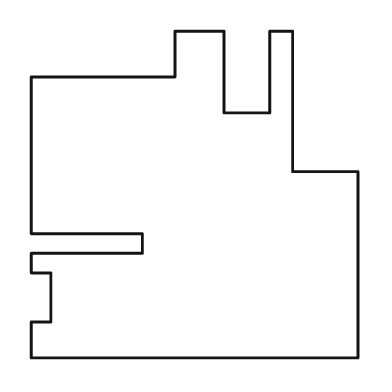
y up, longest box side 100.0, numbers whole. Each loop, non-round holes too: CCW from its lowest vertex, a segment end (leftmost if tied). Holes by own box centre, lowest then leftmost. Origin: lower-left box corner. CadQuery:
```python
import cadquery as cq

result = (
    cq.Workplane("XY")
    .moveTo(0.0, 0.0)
    .lineTo(100.0, 0.0)
    .lineTo(100.0, 57.0)
    .lineTo(80.0, 57.0)
    .lineTo(80.0, 100.0)
    .lineTo(73.0, 100.0)
    .lineTo(73.0, 75.0)
    .lineTo(59.0, 75.0)
    .lineTo(59.0, 100.0)
    .lineTo(44.0, 100.0)
    .lineTo(44.0, 86.0)
    .lineTo(0.0, 86.0)
    .lineTo(0.0, 38.0)
    .lineTo(34.0, 38.0)
    .lineTo(34.0, 32.0)
    .lineTo(0.0, 32.0)
    .lineTo(0.0, 26.0)
    .lineTo(6.0, 26.0)
    .lineTo(6.0, 11.0)
    .lineTo(0.0, 11.0)
    .close()
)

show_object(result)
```